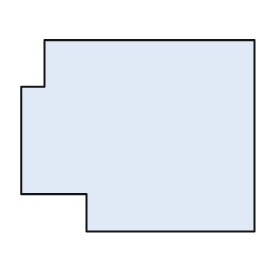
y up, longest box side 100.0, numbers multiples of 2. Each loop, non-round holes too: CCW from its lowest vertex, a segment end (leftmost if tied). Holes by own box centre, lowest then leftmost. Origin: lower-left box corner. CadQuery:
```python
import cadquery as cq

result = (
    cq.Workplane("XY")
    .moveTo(28.0, 0.0)
    .lineTo(100.0, 0.0)
    .lineTo(100.0, 82.0)
    .lineTo(10.0, 82.0)
    .lineTo(10.0, 62.0)
    .lineTo(0.0, 62.0)
    .lineTo(0.0, 16.0)
    .lineTo(28.0, 16.0)
    .close()
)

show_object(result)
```